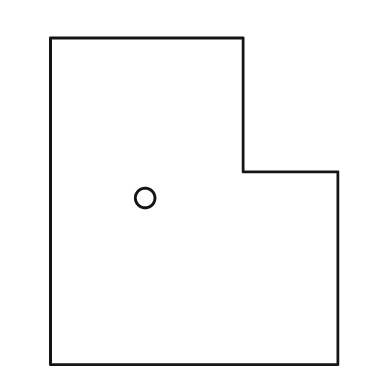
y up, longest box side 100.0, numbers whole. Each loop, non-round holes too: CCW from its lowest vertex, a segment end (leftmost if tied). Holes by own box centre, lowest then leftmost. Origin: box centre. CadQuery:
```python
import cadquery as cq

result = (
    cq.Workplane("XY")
    .moveTo(-44.0, -50.0)
    .lineTo(44.0, -50.0)
    .lineTo(44.0, 9.0)
    .lineTo(15.0, 9.0)
    .lineTo(15.0, 50.0)
    .lineTo(-44.0, 50.0)
    .close()
    .moveTo(-15.0, 1.0)
    .circle(3.0)
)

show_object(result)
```